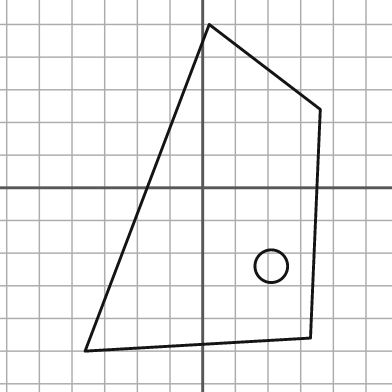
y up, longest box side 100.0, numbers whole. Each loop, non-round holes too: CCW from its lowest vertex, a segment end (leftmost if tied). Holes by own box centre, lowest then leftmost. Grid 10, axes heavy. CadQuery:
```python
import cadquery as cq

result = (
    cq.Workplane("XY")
    .moveTo(-36.0, -50.0)
    .lineTo(33.0, -46.0)
    .lineTo(36.0, 24.0)
    .lineTo(2.0, 50.0)
    .close()
    .moveTo(21.0, -24.0)
    .circle(5.0)
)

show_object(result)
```